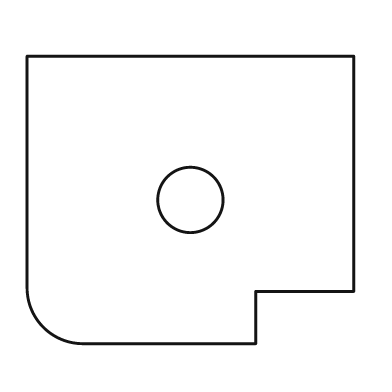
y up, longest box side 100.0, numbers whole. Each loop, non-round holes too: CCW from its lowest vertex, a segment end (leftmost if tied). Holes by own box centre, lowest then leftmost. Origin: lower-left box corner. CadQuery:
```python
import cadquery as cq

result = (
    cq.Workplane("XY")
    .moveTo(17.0, 0.0)
    .lineTo(70.0, 0.0)
    .lineTo(70.0, 16.0)
    .lineTo(100.0, 16.0)
    .lineTo(100.0, 88.0)
    .lineTo(0.0, 88.0)
    .lineTo(0.0, 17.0)
    .threePointArc((5.0, 5.0), (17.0, 0.0))
    .close()
    .moveTo(50.0, 44.0)
    .circle(10.0)
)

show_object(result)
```